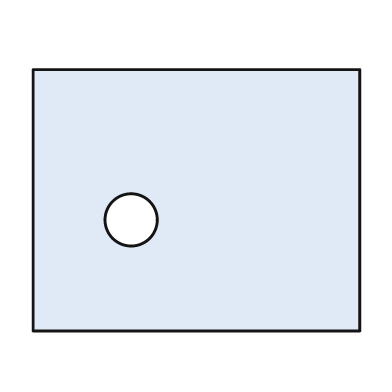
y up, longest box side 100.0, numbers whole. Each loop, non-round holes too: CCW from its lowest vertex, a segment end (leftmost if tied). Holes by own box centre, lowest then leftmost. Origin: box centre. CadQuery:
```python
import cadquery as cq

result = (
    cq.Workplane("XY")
    .moveTo(-50.0, -40.0)
    .lineTo(50.0, -40.0)
    .lineTo(50.0, 40.0)
    .lineTo(-50.0, 40.0)
    .close()
    .moveTo(-20.0, -6.0)
    .circle(8.0)
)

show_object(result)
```